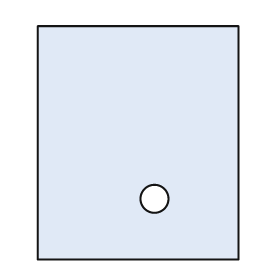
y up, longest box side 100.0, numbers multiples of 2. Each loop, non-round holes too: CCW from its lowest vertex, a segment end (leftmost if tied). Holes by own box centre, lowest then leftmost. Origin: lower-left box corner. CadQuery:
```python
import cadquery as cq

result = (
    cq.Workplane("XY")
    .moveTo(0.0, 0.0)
    .lineTo(86.0, 0.0)
    .lineTo(86.0, 100.0)
    .lineTo(0.0, 100.0)
    .close()
    .moveTo(50.0, 26.0)
    .circle(6.0)
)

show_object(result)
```